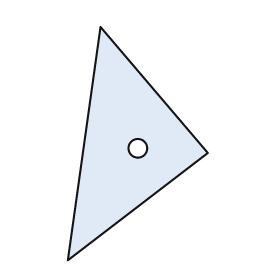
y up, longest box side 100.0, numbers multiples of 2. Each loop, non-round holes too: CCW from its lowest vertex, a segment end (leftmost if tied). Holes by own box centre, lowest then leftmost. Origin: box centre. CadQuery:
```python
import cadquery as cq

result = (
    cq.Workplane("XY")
    .moveTo(-30.0, -50.0)
    .lineTo(30.0, -4.0)
    .lineTo(-16.0, 50.0)
    .close()
    .moveTo(0.0, -2.0)
    .circle(4.0)
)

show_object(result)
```